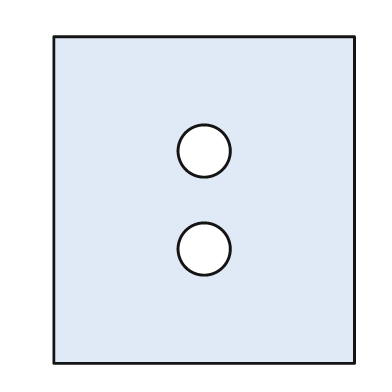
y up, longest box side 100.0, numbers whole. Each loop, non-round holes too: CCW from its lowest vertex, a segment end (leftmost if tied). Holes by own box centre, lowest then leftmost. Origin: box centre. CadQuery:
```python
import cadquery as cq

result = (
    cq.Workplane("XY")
    .moveTo(-46.0, -50.0)
    .lineTo(46.0, -50.0)
    .lineTo(46.0, 50.0)
    .lineTo(-46.0, 50.0)
    .close()
    .moveTo(0.0, -15.0)
    .circle(8.0)
    .moveTo(0.0, 15.0)
    .circle(8.0)
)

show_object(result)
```